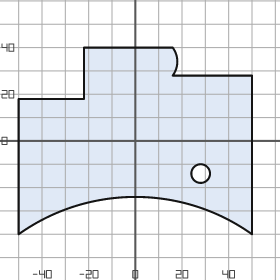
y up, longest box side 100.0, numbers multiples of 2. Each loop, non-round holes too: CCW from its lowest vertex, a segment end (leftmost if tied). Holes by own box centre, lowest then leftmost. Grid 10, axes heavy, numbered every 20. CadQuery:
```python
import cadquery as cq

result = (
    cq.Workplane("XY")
    .moveTo(-50.0, -40.0)
    .threePointArc((0.0, -24.0), (50.0, -40.0))
    .lineTo(50.0, 28.0)
    .lineTo(16.0, 28.0)
    .threePointArc((18.0, 34.0), (16.0, 40.0))
    .lineTo(-22.0, 40.0)
    .lineTo(-22.0, 18.0)
    .lineTo(-50.0, 18.0)
    .close()
    .moveTo(28.0, -14.0)
    .circle(4.0)
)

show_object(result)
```